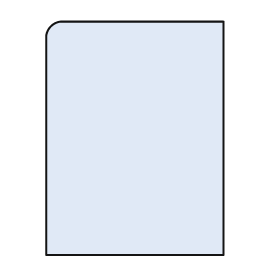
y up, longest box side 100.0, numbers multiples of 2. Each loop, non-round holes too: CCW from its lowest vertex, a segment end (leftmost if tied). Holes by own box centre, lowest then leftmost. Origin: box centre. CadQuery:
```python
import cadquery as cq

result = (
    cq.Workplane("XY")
    .moveTo(-38.0, -50.0)
    .lineTo(38.0, -50.0)
    .lineTo(38.0, 50.0)
    .lineTo(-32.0, 50.0)
    .threePointArc((-36.0, 48.0), (-38.0, 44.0))
    .close()
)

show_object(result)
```